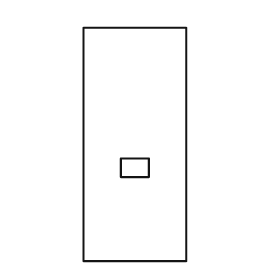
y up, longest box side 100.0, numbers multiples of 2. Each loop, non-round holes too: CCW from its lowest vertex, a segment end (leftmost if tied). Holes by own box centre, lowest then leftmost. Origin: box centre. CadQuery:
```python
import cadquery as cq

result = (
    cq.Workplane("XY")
    .moveTo(-22.0, -50.0)
    .lineTo(22.0, -50.0)
    .lineTo(22.0, 50.0)
    .lineTo(-22.0, 50.0)
    .close()
    .moveTo(-6.0, -14.0)
    .lineTo(6.0, -14.0)
    .lineTo(6.0, -6.0)
    .lineTo(-6.0, -6.0)
    .close()
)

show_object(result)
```